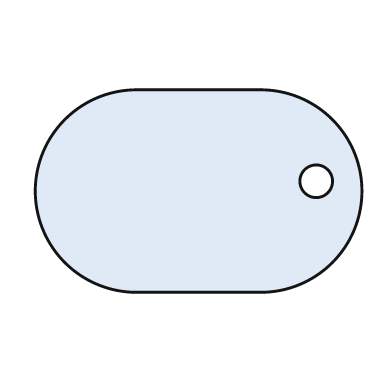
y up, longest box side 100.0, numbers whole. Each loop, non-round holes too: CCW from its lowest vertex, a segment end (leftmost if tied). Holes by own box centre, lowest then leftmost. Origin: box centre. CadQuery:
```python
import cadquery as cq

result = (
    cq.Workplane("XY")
    .moveTo(-19.0, -31.0)
    .lineTo(19.0, -31.0)
    .threePointArc((50.0, 0.0), (19.0, 31.0))
    .lineTo(-19.0, 31.0)
    .threePointArc((-50.0, 0.0), (-19.0, -31.0))
    .close()
    .moveTo(36.0, 3.0)
    .circle(5.0)
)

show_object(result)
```